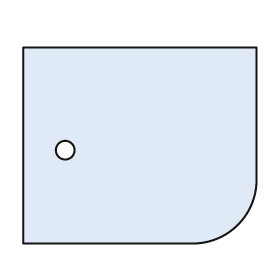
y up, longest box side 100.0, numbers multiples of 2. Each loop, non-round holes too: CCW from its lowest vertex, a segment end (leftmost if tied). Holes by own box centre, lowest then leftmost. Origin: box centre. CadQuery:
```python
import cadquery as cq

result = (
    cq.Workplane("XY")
    .moveTo(-50.0, -42.0)
    .lineTo(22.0, -42.0)
    .threePointArc((42.0, -34.0), (50.0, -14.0))
    .lineTo(50.0, 42.0)
    .lineTo(-50.0, 42.0)
    .close()
    .moveTo(-32.0, -2.0)
    .circle(4.0)
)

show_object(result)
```